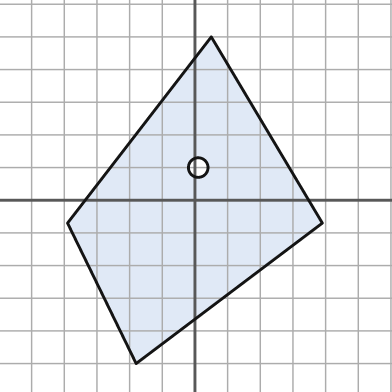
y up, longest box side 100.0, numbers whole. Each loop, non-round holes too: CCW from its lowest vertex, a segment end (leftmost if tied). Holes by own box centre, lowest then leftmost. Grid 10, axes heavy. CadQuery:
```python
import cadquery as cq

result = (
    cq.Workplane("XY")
    .moveTo(-18.0, -50.0)
    .lineTo(39.0, -7.0)
    .lineTo(5.0, 50.0)
    .lineTo(-39.0, -7.0)
    .close()
    .moveTo(1.0, 10.0)
    .circle(3.0)
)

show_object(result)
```